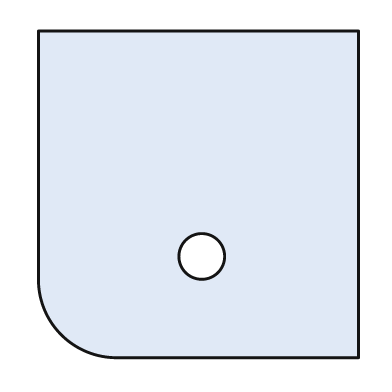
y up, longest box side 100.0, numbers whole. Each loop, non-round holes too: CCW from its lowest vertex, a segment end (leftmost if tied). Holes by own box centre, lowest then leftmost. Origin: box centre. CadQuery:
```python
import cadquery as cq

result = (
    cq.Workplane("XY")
    .moveTo(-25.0, -50.0)
    .lineTo(49.0, -50.0)
    .lineTo(49.0, 50.0)
    .lineTo(-49.0, 50.0)
    .lineTo(-49.0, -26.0)
    .threePointArc((-42.0, -43.0), (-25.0, -50.0))
    .close()
    .moveTo(1.0, -19.0)
    .circle(7.0)
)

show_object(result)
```